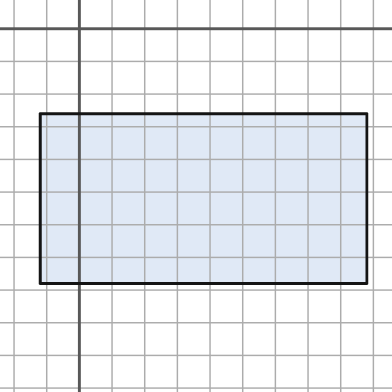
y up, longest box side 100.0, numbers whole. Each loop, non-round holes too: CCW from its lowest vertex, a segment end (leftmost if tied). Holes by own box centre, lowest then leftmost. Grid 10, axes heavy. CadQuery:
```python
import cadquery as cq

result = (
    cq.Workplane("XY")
    .moveTo(-12.0, -78.0)
    .lineTo(88.0, -78.0)
    .lineTo(88.0, -26.0)
    .lineTo(-12.0, -26.0)
    .close()
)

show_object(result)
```